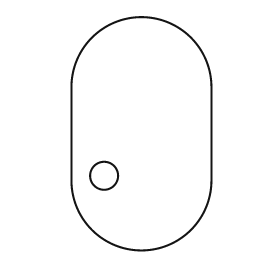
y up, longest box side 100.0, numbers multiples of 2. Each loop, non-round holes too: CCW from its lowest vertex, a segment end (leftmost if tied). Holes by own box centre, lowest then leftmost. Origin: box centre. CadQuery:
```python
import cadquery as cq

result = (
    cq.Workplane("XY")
    .moveTo(-30.0, -20.0)
    .threePointArc((0.0, -50.0), (30.0, -20.0))
    .lineTo(30.0, 20.0)
    .threePointArc((0.0, 50.0), (-30.0, 20.0))
    .close()
    .moveTo(-16.0, -18.0)
    .circle(6.0)
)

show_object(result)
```